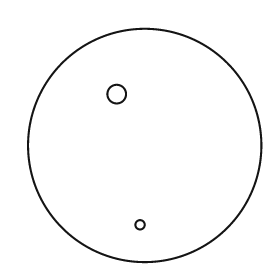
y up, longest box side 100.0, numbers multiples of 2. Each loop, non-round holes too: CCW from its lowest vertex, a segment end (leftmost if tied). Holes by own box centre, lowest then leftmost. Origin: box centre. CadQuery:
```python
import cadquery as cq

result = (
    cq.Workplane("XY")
    .moveTo(0.0, 0.0)
    .circle(50.0)
    .moveTo(-2.0, -34.0)
    .circle(2.0)
    .moveTo(-12.0, 22.0)
    .circle(4.0)
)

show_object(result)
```